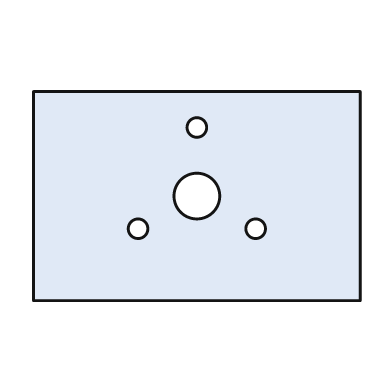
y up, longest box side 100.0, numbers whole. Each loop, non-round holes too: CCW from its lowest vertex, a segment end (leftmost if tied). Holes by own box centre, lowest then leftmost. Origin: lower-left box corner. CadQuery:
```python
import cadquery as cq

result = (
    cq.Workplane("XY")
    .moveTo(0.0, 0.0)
    .lineTo(100.0, 0.0)
    .lineTo(100.0, 64.0)
    .lineTo(0.0, 64.0)
    .close()
    .moveTo(32.0, 22.0)
    .circle(3.0)
    .moveTo(68.0, 22.0)
    .circle(3.0)
    .moveTo(50.0, 32.0)
    .circle(7.0)
    .moveTo(50.0, 53.0)
    .circle(3.0)
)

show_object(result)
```